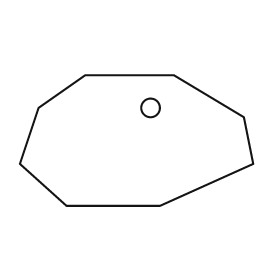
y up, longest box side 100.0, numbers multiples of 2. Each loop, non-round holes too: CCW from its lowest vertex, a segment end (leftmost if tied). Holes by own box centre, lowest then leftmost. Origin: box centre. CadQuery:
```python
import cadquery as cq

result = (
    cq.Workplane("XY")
    .moveTo(-30.0, -28.0)
    .lineTo(10.0, -28.0)
    .lineTo(50.0, -10.0)
    .lineTo(46.0, 10.0)
    .lineTo(16.0, 28.0)
    .lineTo(-22.0, 28.0)
    .lineTo(-42.0, 14.0)
    .lineTo(-50.0, -10.0)
    .close()
    .moveTo(6.0, 14.0)
    .circle(4.0)
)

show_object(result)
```